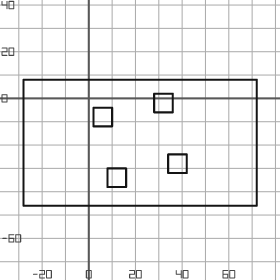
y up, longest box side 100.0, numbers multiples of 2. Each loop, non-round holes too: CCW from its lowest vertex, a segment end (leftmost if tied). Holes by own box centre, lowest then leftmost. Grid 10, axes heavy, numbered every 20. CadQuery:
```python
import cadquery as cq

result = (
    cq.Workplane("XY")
    .moveTo(-28.0, -46.0)
    .lineTo(72.0, -46.0)
    .lineTo(72.0, 8.0)
    .lineTo(-28.0, 8.0)
    .close()
    .moveTo(8.0, -38.0)
    .lineTo(16.0, -38.0)
    .lineTo(16.0, -30.0)
    .lineTo(8.0, -30.0)
    .close()
    .moveTo(34.0, -32.0)
    .lineTo(42.0, -32.0)
    .lineTo(42.0, -24.0)
    .lineTo(34.0, -24.0)
    .close()
    .moveTo(2.0, -12.0)
    .lineTo(10.0, -12.0)
    .lineTo(10.0, -4.0)
    .lineTo(2.0, -4.0)
    .close()
    .moveTo(28.0, -6.0)
    .lineTo(36.0, -6.0)
    .lineTo(36.0, 2.0)
    .lineTo(28.0, 2.0)
    .close()
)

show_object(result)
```